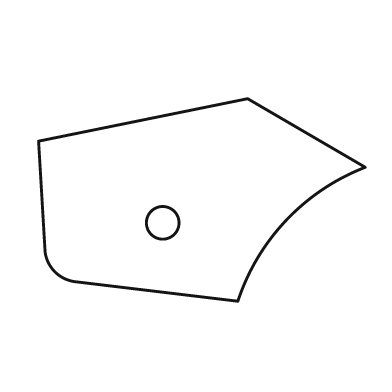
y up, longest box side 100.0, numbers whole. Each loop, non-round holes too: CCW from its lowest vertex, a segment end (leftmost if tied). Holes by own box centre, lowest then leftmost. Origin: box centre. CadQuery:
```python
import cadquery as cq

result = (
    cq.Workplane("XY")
    .moveTo(11.0, -31.0)
    .threePointArc((26.0, -6.0), (50.0, 10.0))
    .lineTo(14.0, 31.0)
    .lineTo(-50.0, 18.0)
    .lineTo(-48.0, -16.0)
    .threePointArc((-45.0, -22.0), (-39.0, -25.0))
    .close()
    .moveTo(-12.0, -7.0)
    .circle(5.0)
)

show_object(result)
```